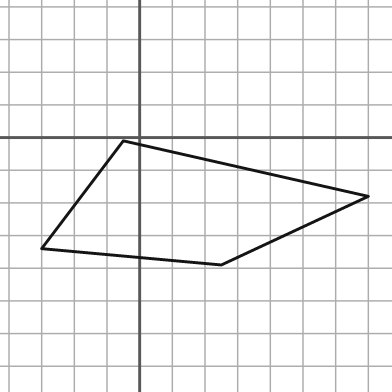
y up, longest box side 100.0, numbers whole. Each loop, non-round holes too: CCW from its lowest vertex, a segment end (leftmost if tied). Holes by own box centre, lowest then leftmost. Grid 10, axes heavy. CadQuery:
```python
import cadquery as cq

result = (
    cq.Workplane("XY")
    .moveTo(25.0, -39.0)
    .lineTo(70.0, -18.0)
    .lineTo(-5.0, -1.0)
    .lineTo(-30.0, -34.0)
    .close()
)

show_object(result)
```